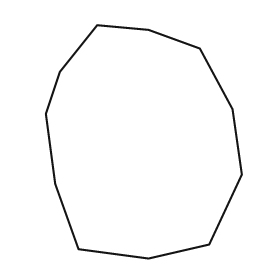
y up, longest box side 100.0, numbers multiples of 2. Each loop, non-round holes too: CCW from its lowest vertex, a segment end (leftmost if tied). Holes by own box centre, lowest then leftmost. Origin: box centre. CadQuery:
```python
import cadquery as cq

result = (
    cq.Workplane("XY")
    .moveTo(2.0, -50.0)
    .lineTo(28.0, -44.0)
    .lineTo(42.0, -14.0)
    .lineTo(38.0, 14.0)
    .lineTo(24.0, 40.0)
    .lineTo(2.0, 48.0)
    .lineTo(-20.0, 50.0)
    .lineTo(-36.0, 30.0)
    .lineTo(-42.0, 12.0)
    .lineTo(-38.0, -18.0)
    .lineTo(-28.0, -46.0)
    .close()
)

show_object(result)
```